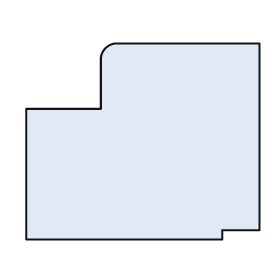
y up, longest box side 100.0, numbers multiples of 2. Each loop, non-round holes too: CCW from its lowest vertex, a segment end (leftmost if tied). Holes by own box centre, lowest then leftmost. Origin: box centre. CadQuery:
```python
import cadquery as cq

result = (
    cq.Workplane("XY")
    .moveTo(-50.0, -42.0)
    .lineTo(34.0, -42.0)
    .lineTo(34.0, -38.0)
    .lineTo(50.0, -38.0)
    .lineTo(50.0, 42.0)
    .lineTo(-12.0, 42.0)
    .threePointArc((-16.0, 40.0), (-18.0, 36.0))
    .lineTo(-18.0, 14.0)
    .lineTo(-50.0, 14.0)
    .close()
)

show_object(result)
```